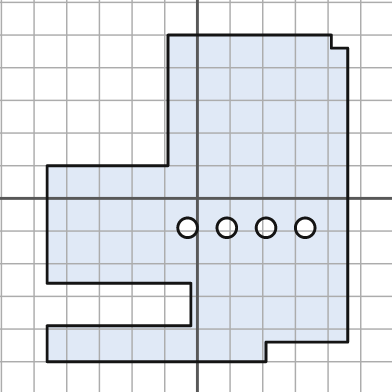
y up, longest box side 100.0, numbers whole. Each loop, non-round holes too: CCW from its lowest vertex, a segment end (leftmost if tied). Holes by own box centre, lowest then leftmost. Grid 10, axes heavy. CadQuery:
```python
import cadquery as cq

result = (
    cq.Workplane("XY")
    .moveTo(-46.0, -50.0)
    .lineTo(21.0, -50.0)
    .lineTo(21.0, -44.0)
    .lineTo(46.0, -44.0)
    .lineTo(46.0, 46.0)
    .lineTo(41.0, 46.0)
    .lineTo(41.0, 50.0)
    .lineTo(-9.0, 50.0)
    .lineTo(-9.0, 10.0)
    .lineTo(-46.0, 10.0)
    .lineTo(-46.0, -26.0)
    .lineTo(-2.0, -26.0)
    .lineTo(-2.0, -39.0)
    .lineTo(-46.0, -39.0)
    .close()
    .moveTo(-3.0, -9.0)
    .circle(3.0)
    .moveTo(9.0, -9.0)
    .circle(3.0)
    .moveTo(21.0, -9.0)
    .circle(3.0)
    .moveTo(33.0, -9.0)
    .circle(3.0)
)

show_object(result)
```